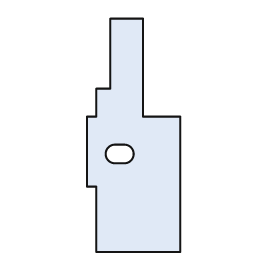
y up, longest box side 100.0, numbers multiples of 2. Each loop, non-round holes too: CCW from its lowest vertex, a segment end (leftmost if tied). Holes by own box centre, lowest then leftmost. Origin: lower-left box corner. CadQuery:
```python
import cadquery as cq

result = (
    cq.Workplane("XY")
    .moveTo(4.0, 0.0)
    .lineTo(40.0, 0.0)
    .lineTo(40.0, 58.0)
    .lineTo(24.0, 58.0)
    .lineTo(24.0, 100.0)
    .lineTo(10.0, 100.0)
    .lineTo(10.0, 70.0)
    .lineTo(4.0, 70.0)
    .lineTo(4.0, 58.0)
    .lineTo(0.0, 58.0)
    .lineTo(0.0, 28.0)
    .lineTo(4.0, 28.0)
    .close()
    .moveTo(12.0, 38.0)
    .lineTo(16.0, 38.0)
    .threePointArc((20.0, 42.0), (16.0, 46.0))
    .lineTo(12.0, 46.0)
    .threePointArc((8.0, 42.0), (12.0, 38.0))
    .close()
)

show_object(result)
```